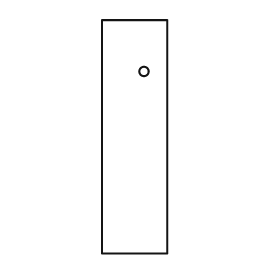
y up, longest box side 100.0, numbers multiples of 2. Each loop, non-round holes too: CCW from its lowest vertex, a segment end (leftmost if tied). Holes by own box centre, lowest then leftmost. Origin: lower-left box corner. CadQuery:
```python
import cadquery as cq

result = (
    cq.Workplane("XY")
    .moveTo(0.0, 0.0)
    .lineTo(28.0, 0.0)
    .lineTo(28.0, 100.0)
    .lineTo(0.0, 100.0)
    .close()
    .moveTo(18.0, 78.0)
    .circle(2.0)
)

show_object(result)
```